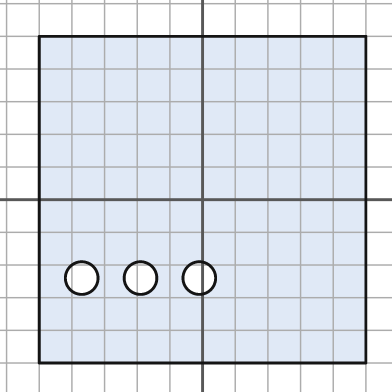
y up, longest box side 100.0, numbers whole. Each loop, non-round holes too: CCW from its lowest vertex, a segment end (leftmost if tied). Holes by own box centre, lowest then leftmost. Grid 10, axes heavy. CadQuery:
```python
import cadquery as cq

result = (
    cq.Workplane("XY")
    .moveTo(-50.0, -50.0)
    .lineTo(50.0, -50.0)
    .lineTo(50.0, 50.0)
    .lineTo(-50.0, 50.0)
    .close()
    .moveTo(-37.0, -24.0)
    .circle(5.0)
    .moveTo(-19.0, -24.0)
    .circle(5.0)
    .moveTo(-1.0, -24.0)
    .circle(5.0)
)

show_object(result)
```